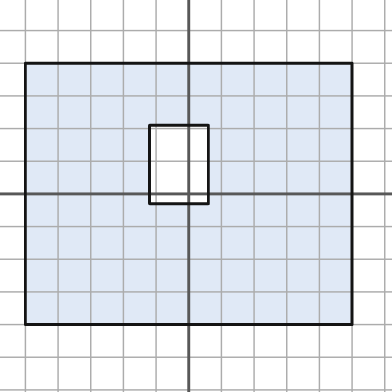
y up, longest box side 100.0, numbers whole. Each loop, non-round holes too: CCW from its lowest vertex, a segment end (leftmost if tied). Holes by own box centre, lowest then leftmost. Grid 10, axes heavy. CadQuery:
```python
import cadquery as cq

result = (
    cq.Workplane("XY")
    .moveTo(-50.0, -40.0)
    .lineTo(50.0, -40.0)
    .lineTo(50.0, 40.0)
    .lineTo(-50.0, 40.0)
    .close()
    .moveTo(-12.0, -3.0)
    .lineTo(6.0, -3.0)
    .lineTo(6.0, 21.0)
    .lineTo(-12.0, 21.0)
    .close()
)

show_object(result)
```